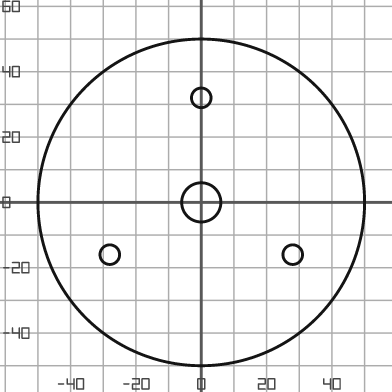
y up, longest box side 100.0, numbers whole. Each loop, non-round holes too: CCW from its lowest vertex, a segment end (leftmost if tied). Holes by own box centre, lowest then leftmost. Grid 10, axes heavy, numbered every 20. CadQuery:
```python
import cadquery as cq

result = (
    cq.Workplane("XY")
    .moveTo(0.0, 0.0)
    .circle(50.0)
    .moveTo(-28.0, -16.0)
    .circle(3.0)
    .moveTo(28.0, -16.0)
    .circle(3.0)
    .moveTo(0.0, 0.0)
    .circle(6.0)
    .moveTo(0.0, 32.0)
    .circle(3.0)
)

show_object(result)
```